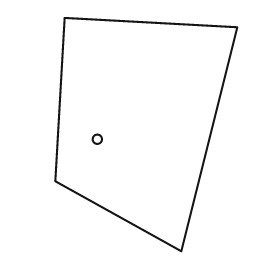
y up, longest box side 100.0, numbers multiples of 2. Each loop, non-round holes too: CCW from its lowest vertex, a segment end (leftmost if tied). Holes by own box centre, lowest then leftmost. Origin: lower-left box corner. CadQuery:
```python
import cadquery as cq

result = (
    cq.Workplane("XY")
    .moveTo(54.0, 0.0)
    .lineTo(78.0, 96.0)
    .lineTo(4.0, 100.0)
    .lineTo(0.0, 30.0)
    .close()
    .moveTo(18.0, 48.0)
    .circle(2.0)
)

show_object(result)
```